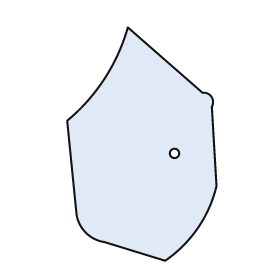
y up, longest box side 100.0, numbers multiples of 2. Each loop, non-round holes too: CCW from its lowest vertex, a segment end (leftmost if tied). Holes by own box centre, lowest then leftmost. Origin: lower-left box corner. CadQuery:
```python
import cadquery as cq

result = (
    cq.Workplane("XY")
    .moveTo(42.0, 0.0)
    .threePointArc((56.0, 14.0), (64.0, 32.0))
    .lineTo(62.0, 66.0)
    .threePointArc((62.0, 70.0), (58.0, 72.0))
    .lineTo(26.0, 100.0)
    .threePointArc((16.0, 78.0), (0.0, 60.0))
    .lineTo(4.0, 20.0)
    .threePointArc((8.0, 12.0), (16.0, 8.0))
    .close()
    .moveTo(46.0, 46.0)
    .circle(2.0)
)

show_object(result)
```